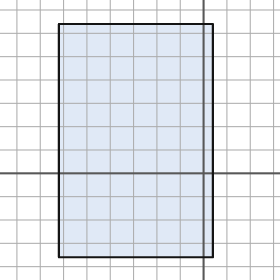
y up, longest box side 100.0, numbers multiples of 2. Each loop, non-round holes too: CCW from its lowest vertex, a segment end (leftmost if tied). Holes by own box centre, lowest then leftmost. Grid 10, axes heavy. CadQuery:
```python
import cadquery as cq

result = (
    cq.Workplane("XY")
    .moveTo(-62.0, -36.0)
    .lineTo(4.0, -36.0)
    .lineTo(4.0, 64.0)
    .lineTo(-62.0, 64.0)
    .close()
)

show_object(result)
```